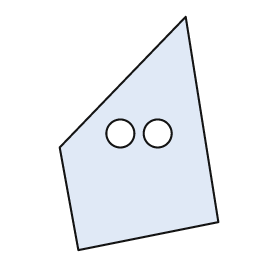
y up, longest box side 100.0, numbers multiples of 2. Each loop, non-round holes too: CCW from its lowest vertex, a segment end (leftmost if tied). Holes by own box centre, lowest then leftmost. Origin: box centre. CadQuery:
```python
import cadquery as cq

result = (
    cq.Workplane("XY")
    .moveTo(-26.0, -50.0)
    .lineTo(34.0, -38.0)
    .lineTo(20.0, 50.0)
    .lineTo(-34.0, -6.0)
    .close()
    .moveTo(-8.0, 0.0)
    .circle(6.0)
    .moveTo(8.0, 0.0)
    .circle(6.0)
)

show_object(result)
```